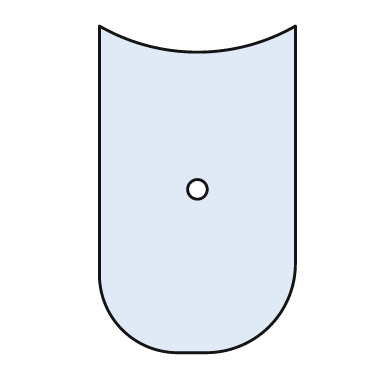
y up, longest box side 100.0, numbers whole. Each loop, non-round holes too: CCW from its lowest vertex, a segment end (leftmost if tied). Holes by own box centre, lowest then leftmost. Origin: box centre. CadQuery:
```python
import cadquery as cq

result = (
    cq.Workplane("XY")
    .moveTo(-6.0, -50.0)
    .lineTo(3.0, -50.0)
    .threePointArc((22.0, -42.0), (30.0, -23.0))
    .lineTo(30.0, 50.0)
    .threePointArc((0.0, 42.0), (-30.0, 50.0))
    .lineTo(-30.0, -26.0)
    .threePointArc((-23.0, -43.0), (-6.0, -50.0))
    .close()
    .moveTo(0.0, 0.0)
    .circle(3.0)
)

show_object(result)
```